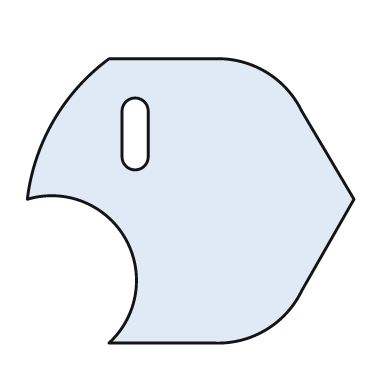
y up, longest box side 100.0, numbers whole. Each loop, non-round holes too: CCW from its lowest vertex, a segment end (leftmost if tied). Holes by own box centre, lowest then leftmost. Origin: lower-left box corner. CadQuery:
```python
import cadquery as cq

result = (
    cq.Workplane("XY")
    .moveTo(25.0, 0.0)
    .lineTo(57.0, 0.0)
    .threePointArc((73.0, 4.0), (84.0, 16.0))
    .lineTo(100.0, 44.0)
    .lineTo(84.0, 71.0)
    .threePointArc((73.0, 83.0), (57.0, 87.0))
    .lineTo(25.0, 87.0)
    .threePointArc((8.0, 68.0), (0.0, 44.0))
    .threePointArc((30.0, 32.0), (25.0, 0.0))
    .close()
    .moveTo(29.0, 57.0)
    .threePointArc((33.0, 53.0), (37.0, 57.0))
    .lineTo(37.0, 71.0)
    .threePointArc((33.0, 75.0), (29.0, 71.0))
    .close()
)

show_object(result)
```